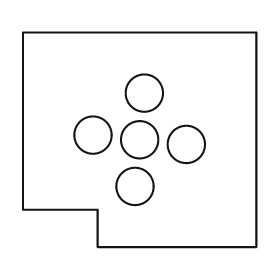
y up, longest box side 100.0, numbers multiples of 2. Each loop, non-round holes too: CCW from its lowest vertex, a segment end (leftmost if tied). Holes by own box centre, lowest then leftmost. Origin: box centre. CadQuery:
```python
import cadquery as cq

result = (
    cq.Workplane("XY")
    .moveTo(-18.0, -46.0)
    .lineTo(50.0, -46.0)
    .lineTo(50.0, 46.0)
    .lineTo(-50.0, 46.0)
    .lineTo(-50.0, -30.0)
    .lineTo(-18.0, -30.0)
    .close()
    .moveTo(-2.0, -20.0)
    .circle(8.0)
    .moveTo(20.0, -2.0)
    .circle(8.0)
    .moveTo(0.0, 0.0)
    .circle(8.0)
    .moveTo(-20.0, 2.0)
    .circle(8.0)
    .moveTo(2.0, 20.0)
    .circle(8.0)
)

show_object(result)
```